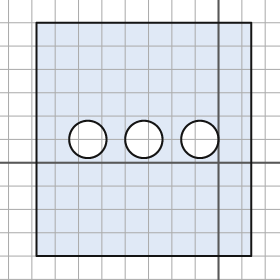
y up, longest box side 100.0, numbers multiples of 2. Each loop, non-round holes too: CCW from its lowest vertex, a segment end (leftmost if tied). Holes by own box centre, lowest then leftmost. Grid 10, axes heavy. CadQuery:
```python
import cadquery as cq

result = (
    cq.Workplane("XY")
    .moveTo(-78.0, -40.0)
    .lineTo(14.0, -40.0)
    .lineTo(14.0, 60.0)
    .lineTo(-78.0, 60.0)
    .close()
    .moveTo(-56.0, 10.0)
    .circle(8.0)
    .moveTo(-32.0, 10.0)
    .circle(8.0)
    .moveTo(-8.0, 10.0)
    .circle(8.0)
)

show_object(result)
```